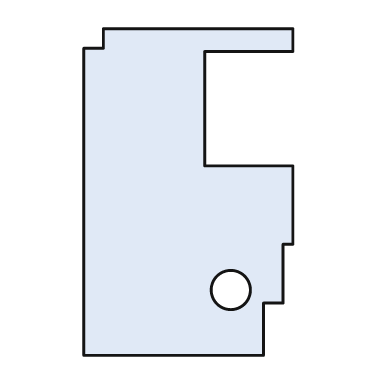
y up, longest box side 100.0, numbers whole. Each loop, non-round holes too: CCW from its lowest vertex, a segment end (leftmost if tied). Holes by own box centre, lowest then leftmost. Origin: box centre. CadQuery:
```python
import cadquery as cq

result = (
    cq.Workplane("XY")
    .moveTo(-32.0, -50.0)
    .lineTo(23.0, -50.0)
    .lineTo(23.0, -34.0)
    .lineTo(29.0, -34.0)
    .lineTo(29.0, -16.0)
    .lineTo(32.0, -16.0)
    .lineTo(32.0, 8.0)
    .lineTo(5.0, 8.0)
    .lineTo(5.0, 43.0)
    .lineTo(32.0, 43.0)
    .lineTo(32.0, 50.0)
    .lineTo(-26.0, 50.0)
    .lineTo(-26.0, 44.0)
    .lineTo(-32.0, 44.0)
    .close()
    .moveTo(13.0, -30.0)
    .circle(6.0)
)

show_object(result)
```